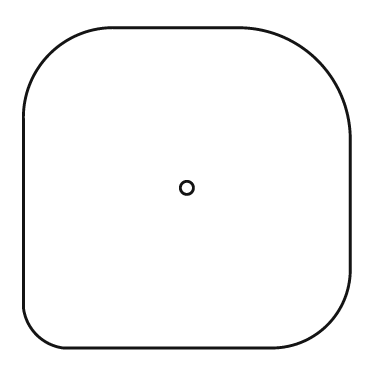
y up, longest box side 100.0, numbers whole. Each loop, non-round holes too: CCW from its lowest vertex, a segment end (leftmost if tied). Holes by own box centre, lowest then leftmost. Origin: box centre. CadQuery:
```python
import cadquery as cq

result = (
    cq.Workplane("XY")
    .moveTo(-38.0, -49.0)
    .lineTo(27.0, -49.0)
    .threePointArc((43.0, -42.0), (50.0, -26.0))
    .lineTo(50.0, 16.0)
    .threePointArc((40.0, 39.0), (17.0, 49.0))
    .lineTo(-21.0, 49.0)
    .threePointArc((-42.0, 41.0), (-50.0, 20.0))
    .lineTo(-50.0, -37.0)
    .threePointArc((-46.0, -45.0), (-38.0, -49.0))
    .close()
    .moveTo(0.0, 0.0)
    .circle(2.0)
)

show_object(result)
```